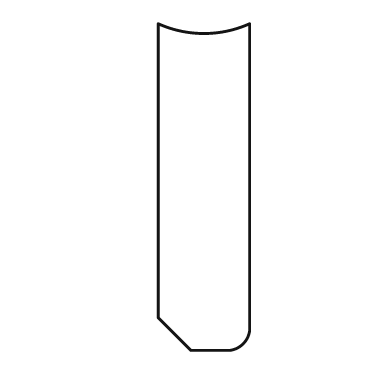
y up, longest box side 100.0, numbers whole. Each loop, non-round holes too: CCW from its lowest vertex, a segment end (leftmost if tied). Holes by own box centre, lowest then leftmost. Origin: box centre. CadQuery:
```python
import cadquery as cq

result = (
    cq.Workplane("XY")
    .moveTo(-4.0, -50.0)
    .lineTo(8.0, -50.0)
    .threePointArc((12.0, -48.0), (14.0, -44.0))
    .lineTo(14.0, 50.0)
    .threePointArc((0.0, 47.0), (-14.0, 50.0))
    .lineTo(-14.0, -40.0)
    .close()
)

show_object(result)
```